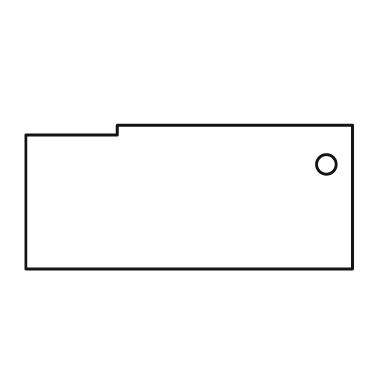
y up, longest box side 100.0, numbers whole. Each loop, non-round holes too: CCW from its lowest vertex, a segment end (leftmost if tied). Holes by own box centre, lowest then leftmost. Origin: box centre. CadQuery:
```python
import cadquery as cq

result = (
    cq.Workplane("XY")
    .moveTo(-50.0, -22.0)
    .lineTo(50.0, -22.0)
    .lineTo(50.0, 22.0)
    .lineTo(-22.0, 22.0)
    .lineTo(-22.0, 19.0)
    .lineTo(-50.0, 19.0)
    .close()
    .moveTo(42.0, 10.0)
    .circle(3.0)
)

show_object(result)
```